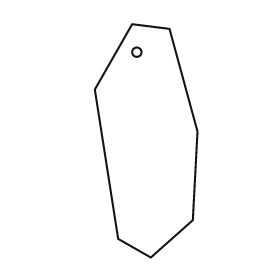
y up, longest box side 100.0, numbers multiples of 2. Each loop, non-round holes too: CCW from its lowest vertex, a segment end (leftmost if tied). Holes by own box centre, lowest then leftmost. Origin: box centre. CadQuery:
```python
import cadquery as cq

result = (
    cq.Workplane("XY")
    .moveTo(2.0, -50.0)
    .lineTo(20.0, -34.0)
    .lineTo(22.0, 4.0)
    .lineTo(10.0, 48.0)
    .lineTo(-6.0, 50.0)
    .lineTo(-22.0, 22.0)
    .lineTo(-12.0, -42.0)
    .close()
    .moveTo(-4.0, 38.0)
    .circle(2.0)
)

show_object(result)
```